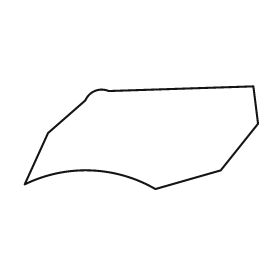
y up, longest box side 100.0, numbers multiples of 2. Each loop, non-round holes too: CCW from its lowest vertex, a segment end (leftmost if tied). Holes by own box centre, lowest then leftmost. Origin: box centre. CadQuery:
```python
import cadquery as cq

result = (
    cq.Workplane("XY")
    .moveTo(6.0, -22.0)
    .lineTo(34.0, -14.0)
    .lineTo(50.0, 6.0)
    .lineTo(48.0, 22.0)
    .lineTo(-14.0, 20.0)
    .threePointArc((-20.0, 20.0), (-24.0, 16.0))
    .lineTo(-40.0, 2.0)
    .lineTo(-50.0, -20.0)
    .threePointArc((-22.0, -14.0), (6.0, -22.0))
    .close()
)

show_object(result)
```